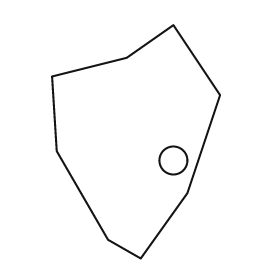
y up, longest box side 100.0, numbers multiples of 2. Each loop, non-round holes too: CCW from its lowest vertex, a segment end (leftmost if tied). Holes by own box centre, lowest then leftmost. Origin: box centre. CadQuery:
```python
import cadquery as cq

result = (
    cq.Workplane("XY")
    .moveTo(2.0, -50.0)
    .lineTo(22.0, -22.0)
    .lineTo(36.0, 20.0)
    .lineTo(16.0, 50.0)
    .lineTo(-4.0, 36.0)
    .lineTo(-36.0, 28.0)
    .lineTo(-34.0, -4.0)
    .lineTo(-12.0, -42.0)
    .close()
    .moveTo(16.0, -8.0)
    .circle(6.0)
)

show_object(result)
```